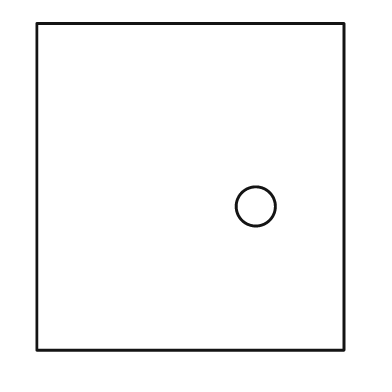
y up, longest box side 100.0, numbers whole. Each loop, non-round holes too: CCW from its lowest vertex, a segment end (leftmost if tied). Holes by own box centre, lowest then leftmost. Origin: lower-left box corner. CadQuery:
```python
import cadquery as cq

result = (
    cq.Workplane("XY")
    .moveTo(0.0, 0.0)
    .lineTo(94.0, 0.0)
    .lineTo(94.0, 100.0)
    .lineTo(0.0, 100.0)
    .close()
    .moveTo(67.0, 44.0)
    .circle(6.0)
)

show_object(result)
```